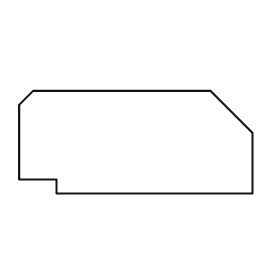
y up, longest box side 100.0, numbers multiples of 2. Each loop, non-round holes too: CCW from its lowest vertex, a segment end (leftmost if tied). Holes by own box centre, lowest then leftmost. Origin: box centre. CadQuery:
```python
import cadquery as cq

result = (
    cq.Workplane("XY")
    .moveTo(-34.0, -22.0)
    .lineTo(50.0, -22.0)
    .lineTo(50.0, 4.0)
    .lineTo(32.0, 22.0)
    .lineTo(-44.0, 22.0)
    .lineTo(-50.0, 16.0)
    .lineTo(-50.0, -16.0)
    .lineTo(-34.0, -16.0)
    .close()
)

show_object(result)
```